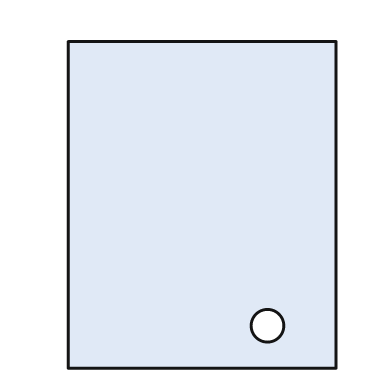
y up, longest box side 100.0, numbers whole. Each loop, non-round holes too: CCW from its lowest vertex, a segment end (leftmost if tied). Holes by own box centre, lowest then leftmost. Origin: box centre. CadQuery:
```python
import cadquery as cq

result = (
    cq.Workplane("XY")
    .moveTo(-41.0, -50.0)
    .lineTo(41.0, -50.0)
    .lineTo(41.0, 50.0)
    .lineTo(-41.0, 50.0)
    .close()
    .moveTo(20.0, -37.0)
    .circle(5.0)
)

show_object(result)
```